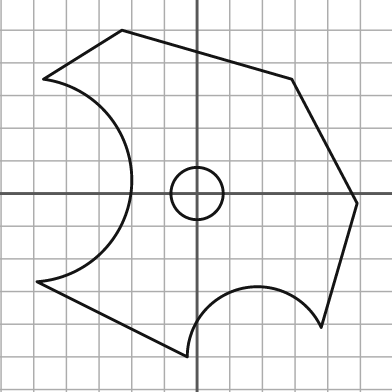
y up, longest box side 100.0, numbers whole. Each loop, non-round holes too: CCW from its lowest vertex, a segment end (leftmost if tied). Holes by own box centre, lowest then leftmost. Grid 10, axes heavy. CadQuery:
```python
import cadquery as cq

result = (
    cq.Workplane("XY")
    .moveTo(-3.0, -50.0)
    .threePointArc((14.0, -29.0), (38.0, -41.0))
    .lineTo(49.0, -3.0)
    .lineTo(29.0, 35.0)
    .lineTo(-23.0, 50.0)
    .lineTo(-47.0, 35.0)
    .threePointArc((-20.0, 3.0), (-49.0, -27.0))
    .close()
    .moveTo(0.0, 0.0)
    .circle(8.0)
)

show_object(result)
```